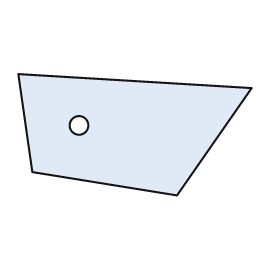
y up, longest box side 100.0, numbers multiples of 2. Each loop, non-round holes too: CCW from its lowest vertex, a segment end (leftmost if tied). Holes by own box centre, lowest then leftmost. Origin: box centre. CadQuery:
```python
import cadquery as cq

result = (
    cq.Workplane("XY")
    .moveTo(18.0, -26.0)
    .lineTo(50.0, 20.0)
    .lineTo(-50.0, 26.0)
    .lineTo(-44.0, -16.0)
    .close()
    .moveTo(-24.0, 4.0)
    .circle(4.0)
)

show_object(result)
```